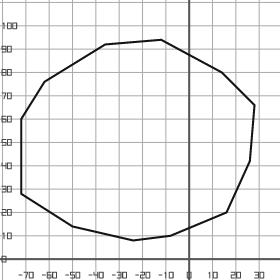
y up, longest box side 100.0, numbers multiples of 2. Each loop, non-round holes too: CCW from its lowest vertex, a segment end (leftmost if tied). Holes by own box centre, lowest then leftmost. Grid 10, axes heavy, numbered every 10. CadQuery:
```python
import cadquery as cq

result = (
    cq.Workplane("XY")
    .moveTo(-24.0, 8.0)
    .lineTo(-8.0, 10.0)
    .lineTo(16.0, 20.0)
    .lineTo(26.0, 42.0)
    .lineTo(28.0, 66.0)
    .lineTo(14.0, 80.0)
    .lineTo(-12.0, 94.0)
    .lineTo(-36.0, 92.0)
    .lineTo(-62.0, 76.0)
    .lineTo(-72.0, 60.0)
    .lineTo(-72.0, 28.0)
    .lineTo(-50.0, 14.0)
    .close()
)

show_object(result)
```